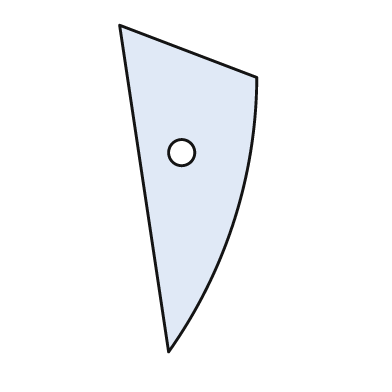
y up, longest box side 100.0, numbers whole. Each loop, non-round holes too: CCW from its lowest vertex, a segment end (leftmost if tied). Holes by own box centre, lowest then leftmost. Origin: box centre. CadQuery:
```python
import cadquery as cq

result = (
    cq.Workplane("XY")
    .moveTo(-6.0, -50.0)
    .threePointArc((14.0, -10.0), (21.0, 34.0))
    .lineTo(-21.0, 50.0)
    .close()
    .moveTo(-2.0, 11.0)
    .circle(4.0)
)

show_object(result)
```